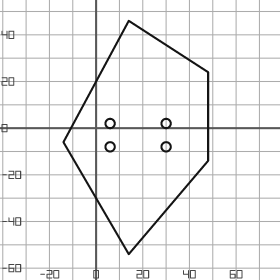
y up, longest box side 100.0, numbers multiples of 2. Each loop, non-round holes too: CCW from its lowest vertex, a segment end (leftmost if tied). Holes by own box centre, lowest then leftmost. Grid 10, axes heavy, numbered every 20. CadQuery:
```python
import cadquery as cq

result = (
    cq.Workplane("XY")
    .moveTo(14.0, -54.0)
    .lineTo(48.0, -14.0)
    .lineTo(48.0, 24.0)
    .lineTo(14.0, 46.0)
    .lineTo(-14.0, -6.0)
    .close()
    .moveTo(6.0, -8.0)
    .circle(2.0)
    .moveTo(30.0, -8.0)
    .circle(2.0)
    .moveTo(6.0, 2.0)
    .circle(2.0)
    .moveTo(30.0, 2.0)
    .circle(2.0)
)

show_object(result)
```